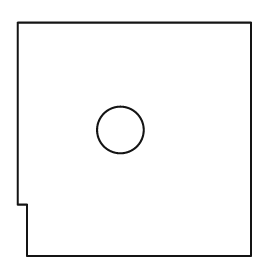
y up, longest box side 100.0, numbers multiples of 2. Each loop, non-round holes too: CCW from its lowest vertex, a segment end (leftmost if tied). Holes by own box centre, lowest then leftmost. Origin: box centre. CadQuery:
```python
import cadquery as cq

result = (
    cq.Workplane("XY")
    .moveTo(-46.0, -50.0)
    .lineTo(50.0, -50.0)
    .lineTo(50.0, 50.0)
    .lineTo(-50.0, 50.0)
    .lineTo(-50.0, -28.0)
    .lineTo(-46.0, -28.0)
    .close()
    .moveTo(-6.0, 4.0)
    .circle(10.0)
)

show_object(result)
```